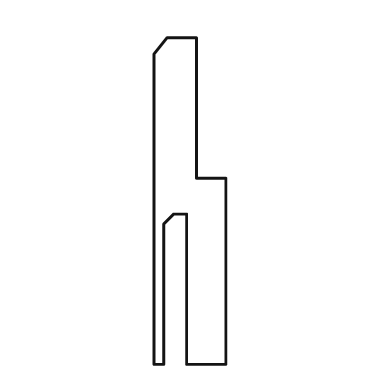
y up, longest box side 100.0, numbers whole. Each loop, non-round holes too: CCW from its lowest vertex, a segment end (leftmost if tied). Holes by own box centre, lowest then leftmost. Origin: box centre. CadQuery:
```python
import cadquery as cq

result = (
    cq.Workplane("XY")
    .moveTo(-11.0, -50.0)
    .lineTo(-8.0, -50.0)
    .lineTo(-8.0, -7.0)
    .lineTo(-5.0, -4.0)
    .lineTo(-1.0, -4.0)
    .lineTo(-1.0, -50.0)
    .lineTo(11.0, -50.0)
    .lineTo(11.0, 7.0)
    .lineTo(2.0, 7.0)
    .lineTo(2.0, 50.0)
    .lineTo(-7.0, 50.0)
    .lineTo(-11.0, 45.0)
    .close()
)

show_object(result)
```